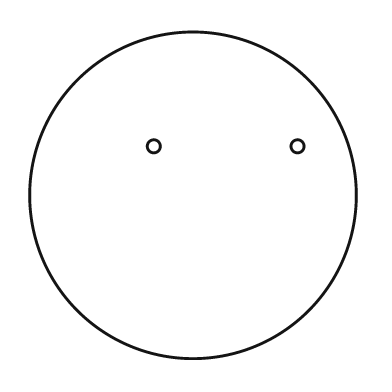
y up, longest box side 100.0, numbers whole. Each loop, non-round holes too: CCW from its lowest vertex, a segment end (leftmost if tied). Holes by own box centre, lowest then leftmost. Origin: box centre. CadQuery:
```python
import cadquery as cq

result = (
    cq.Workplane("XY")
    .moveTo(0.0, 0.0)
    .circle(50.0)
    .moveTo(-12.0, 15.0)
    .circle(2.0)
    .moveTo(32.0, 15.0)
    .circle(2.0)
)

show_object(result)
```